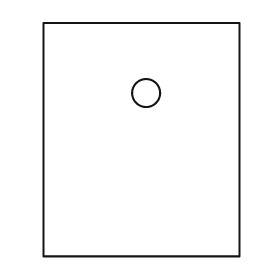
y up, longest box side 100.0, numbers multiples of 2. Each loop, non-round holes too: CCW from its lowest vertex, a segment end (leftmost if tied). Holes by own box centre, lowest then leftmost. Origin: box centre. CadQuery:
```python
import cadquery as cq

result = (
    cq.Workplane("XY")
    .moveTo(-42.0, -50.0)
    .lineTo(42.0, -50.0)
    .lineTo(42.0, 50.0)
    .lineTo(-42.0, 50.0)
    .close()
    .moveTo(2.0, 20.0)
    .circle(6.0)
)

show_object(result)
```